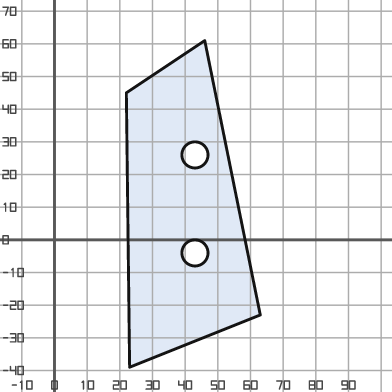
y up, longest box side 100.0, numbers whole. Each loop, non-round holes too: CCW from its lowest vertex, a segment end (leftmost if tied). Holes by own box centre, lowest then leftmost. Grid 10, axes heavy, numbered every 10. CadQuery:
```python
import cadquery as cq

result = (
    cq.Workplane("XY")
    .moveTo(23.0, -39.0)
    .lineTo(63.0, -23.0)
    .lineTo(46.0, 61.0)
    .lineTo(22.0, 45.0)
    .close()
    .moveTo(43.0, -4.0)
    .circle(4.0)
    .moveTo(43.0, 26.0)
    .circle(4.0)
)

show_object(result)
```